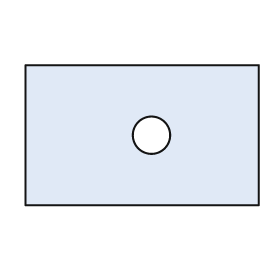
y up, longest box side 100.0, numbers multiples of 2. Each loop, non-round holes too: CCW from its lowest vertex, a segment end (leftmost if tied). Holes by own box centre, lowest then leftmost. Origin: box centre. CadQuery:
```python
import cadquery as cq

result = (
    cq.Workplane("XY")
    .moveTo(-50.0, -30.0)
    .lineTo(50.0, -30.0)
    .lineTo(50.0, 30.0)
    .lineTo(-50.0, 30.0)
    .close()
    .moveTo(4.0, 0.0)
    .circle(8.0)
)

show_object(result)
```